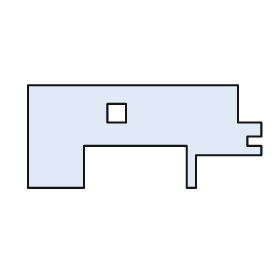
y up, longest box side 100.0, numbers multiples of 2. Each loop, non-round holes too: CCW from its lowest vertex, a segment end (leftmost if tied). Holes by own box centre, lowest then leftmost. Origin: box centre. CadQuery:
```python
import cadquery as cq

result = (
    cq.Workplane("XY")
    .moveTo(-50.0, -22.0)
    .lineTo(-26.0, -22.0)
    .lineTo(-26.0, -4.0)
    .lineTo(18.0, -4.0)
    .lineTo(18.0, -22.0)
    .lineTo(22.0, -22.0)
    .lineTo(22.0, -8.0)
    .lineTo(50.0, -8.0)
    .lineTo(50.0, -4.0)
    .lineTo(44.0, -4.0)
    .lineTo(44.0, 0.0)
    .lineTo(50.0, 0.0)
    .lineTo(50.0, 6.0)
    .lineTo(40.0, 6.0)
    .lineTo(40.0, 22.0)
    .lineTo(-50.0, 22.0)
    .close()
    .moveTo(-16.0, 6.0)
    .lineTo(-8.0, 6.0)
    .lineTo(-8.0, 14.0)
    .lineTo(-16.0, 14.0)
    .close()
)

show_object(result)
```